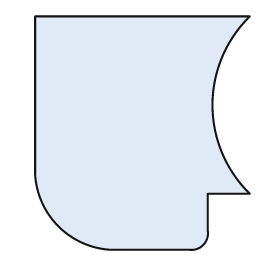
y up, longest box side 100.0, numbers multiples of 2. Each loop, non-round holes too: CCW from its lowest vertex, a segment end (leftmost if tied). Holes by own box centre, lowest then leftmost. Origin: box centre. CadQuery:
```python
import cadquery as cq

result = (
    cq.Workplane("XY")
    .moveTo(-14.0, -50.0)
    .lineTo(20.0, -50.0)
    .threePointArc((26.0, -48.0), (28.0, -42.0))
    .lineTo(28.0, -26.0)
    .lineTo(46.0, -26.0)
    .threePointArc((30.0, 12.0), (46.0, 50.0))
    .lineTo(-46.0, 50.0)
    .lineTo(-46.0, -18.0)
    .threePointArc((-36.0, -40.0), (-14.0, -50.0))
    .close()
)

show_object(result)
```